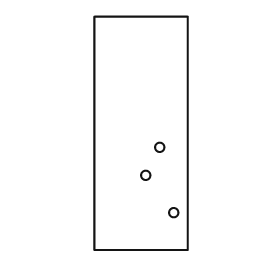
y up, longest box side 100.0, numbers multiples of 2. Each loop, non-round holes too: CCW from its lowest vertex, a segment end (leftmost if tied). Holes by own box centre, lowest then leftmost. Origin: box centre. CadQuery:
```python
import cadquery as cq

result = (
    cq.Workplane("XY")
    .moveTo(-20.0, -50.0)
    .lineTo(20.0, -50.0)
    .lineTo(20.0, 50.0)
    .lineTo(-20.0, 50.0)
    .close()
    .moveTo(14.0, -34.0)
    .circle(2.0)
    .moveTo(2.0, -18.0)
    .circle(2.0)
    .moveTo(8.0, -6.0)
    .circle(2.0)
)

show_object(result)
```